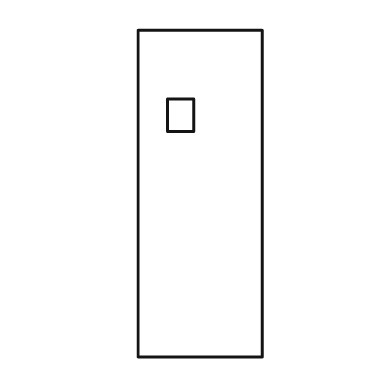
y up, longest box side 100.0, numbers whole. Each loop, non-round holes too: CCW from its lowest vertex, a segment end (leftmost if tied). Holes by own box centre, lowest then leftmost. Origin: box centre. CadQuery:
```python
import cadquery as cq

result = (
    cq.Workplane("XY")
    .moveTo(-19.0, -50.0)
    .lineTo(19.0, -50.0)
    .lineTo(19.0, 50.0)
    .lineTo(-19.0, 50.0)
    .close()
    .moveTo(-10.0, 19.0)
    .lineTo(-2.0, 19.0)
    .lineTo(-2.0, 29.0)
    .lineTo(-10.0, 29.0)
    .close()
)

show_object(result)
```